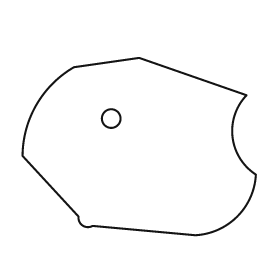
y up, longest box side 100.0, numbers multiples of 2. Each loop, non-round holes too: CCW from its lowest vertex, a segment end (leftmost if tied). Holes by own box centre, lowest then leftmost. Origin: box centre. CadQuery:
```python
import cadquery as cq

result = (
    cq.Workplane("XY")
    .moveTo(24.0, -38.0)
    .threePointArc((42.0, -30.0), (50.0, -12.0))
    .threePointArc((40.0, 4.0), (46.0, 22.0))
    .lineTo(0.0, 38.0)
    .lineTo(-28.0, 34.0)
    .threePointArc((-44.0, 18.0), (-50.0, -4.0))
    .lineTo(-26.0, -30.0)
    .threePointArc((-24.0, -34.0), (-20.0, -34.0))
    .close()
    .moveTo(-12.0, 12.0)
    .circle(4.0)
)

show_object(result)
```